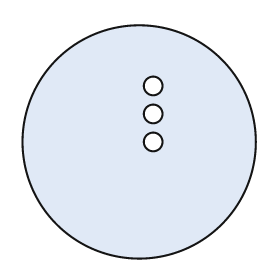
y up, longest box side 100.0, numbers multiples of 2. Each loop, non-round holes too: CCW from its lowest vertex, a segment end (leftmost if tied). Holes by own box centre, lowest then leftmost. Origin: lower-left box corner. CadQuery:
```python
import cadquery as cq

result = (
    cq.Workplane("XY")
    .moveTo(50.0, 50.0)
    .circle(50.0)
    .moveTo(56.0, 50.0)
    .circle(4.0)
    .moveTo(56.0, 62.0)
    .circle(4.0)
    .moveTo(56.0, 74.0)
    .circle(4.0)
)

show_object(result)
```